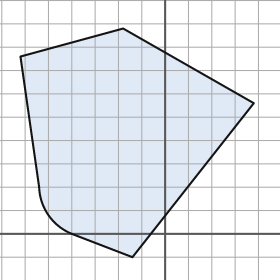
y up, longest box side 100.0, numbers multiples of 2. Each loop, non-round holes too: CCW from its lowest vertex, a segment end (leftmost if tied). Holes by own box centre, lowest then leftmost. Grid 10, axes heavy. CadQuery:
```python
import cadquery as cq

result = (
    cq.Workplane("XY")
    .moveTo(-14.0, -10.0)
    .lineTo(38.0, 56.0)
    .lineTo(-18.0, 88.0)
    .lineTo(-62.0, 76.0)
    .lineTo(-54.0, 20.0)
    .threePointArc((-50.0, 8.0), (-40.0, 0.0))
    .close()
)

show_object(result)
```